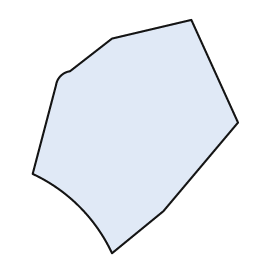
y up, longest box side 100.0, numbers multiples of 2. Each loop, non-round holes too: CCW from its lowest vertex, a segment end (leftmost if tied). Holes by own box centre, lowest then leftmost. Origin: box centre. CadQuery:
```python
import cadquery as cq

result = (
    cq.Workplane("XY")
    .moveTo(-10.0, -50.0)
    .lineTo(12.0, -32.0)
    .lineTo(44.0, 6.0)
    .lineTo(24.0, 50.0)
    .lineTo(-10.0, 42.0)
    .lineTo(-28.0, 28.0)
    .threePointArc((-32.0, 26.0), (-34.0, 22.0))
    .lineTo(-44.0, -16.0)
    .threePointArc((-24.0, -30.0), (-10.0, -50.0))
    .close()
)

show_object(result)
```